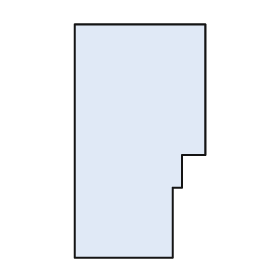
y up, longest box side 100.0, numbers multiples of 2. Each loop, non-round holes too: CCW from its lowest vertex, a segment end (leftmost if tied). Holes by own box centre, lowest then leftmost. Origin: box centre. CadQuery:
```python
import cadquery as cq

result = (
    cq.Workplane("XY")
    .moveTo(-28.0, -50.0)
    .lineTo(14.0, -50.0)
    .lineTo(14.0, -20.0)
    .lineTo(18.0, -20.0)
    .lineTo(18.0, -6.0)
    .lineTo(28.0, -6.0)
    .lineTo(28.0, 50.0)
    .lineTo(-28.0, 50.0)
    .close()
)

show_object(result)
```